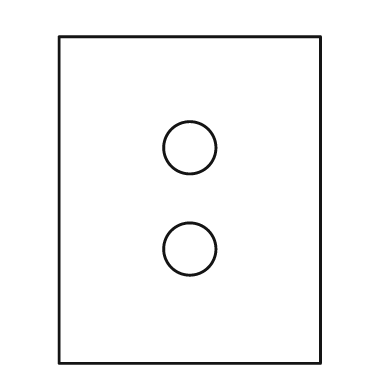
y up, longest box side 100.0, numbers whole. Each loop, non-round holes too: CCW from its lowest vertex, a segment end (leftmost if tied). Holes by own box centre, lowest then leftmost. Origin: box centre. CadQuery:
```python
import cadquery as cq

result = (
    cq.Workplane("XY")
    .moveTo(-40.0, -50.0)
    .lineTo(40.0, -50.0)
    .lineTo(40.0, 50.0)
    .lineTo(-40.0, 50.0)
    .close()
    .moveTo(0.0, -15.0)
    .circle(8.0)
    .moveTo(0.0, 16.0)
    .circle(8.0)
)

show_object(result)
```